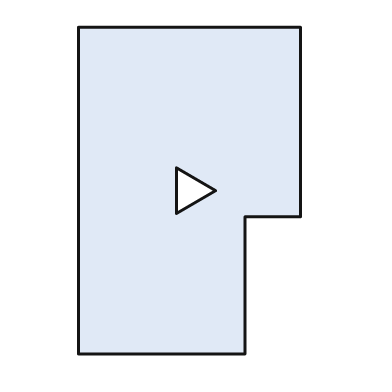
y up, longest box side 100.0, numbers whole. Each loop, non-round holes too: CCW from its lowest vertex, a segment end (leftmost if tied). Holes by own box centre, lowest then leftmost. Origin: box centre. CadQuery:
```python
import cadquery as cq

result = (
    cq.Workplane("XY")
    .moveTo(-34.0, -50.0)
    .lineTo(17.0, -50.0)
    .lineTo(17.0, -8.0)
    .lineTo(34.0, -8.0)
    .lineTo(34.0, 50.0)
    .lineTo(-34.0, 50.0)
    .close()
    .moveTo(-4.0, -7.0)
    .lineTo(8.0, 0.0)
    .lineTo(-4.0, 7.0)
    .close()
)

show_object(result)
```